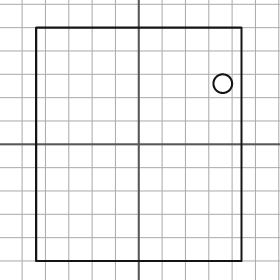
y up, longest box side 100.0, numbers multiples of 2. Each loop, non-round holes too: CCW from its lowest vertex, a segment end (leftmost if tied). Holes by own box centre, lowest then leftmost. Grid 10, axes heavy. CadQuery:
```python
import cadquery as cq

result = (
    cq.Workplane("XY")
    .moveTo(-44.0, -50.0)
    .lineTo(44.0, -50.0)
    .lineTo(44.0, 50.0)
    .lineTo(-44.0, 50.0)
    .close()
    .moveTo(36.0, 26.0)
    .circle(4.0)
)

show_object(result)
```